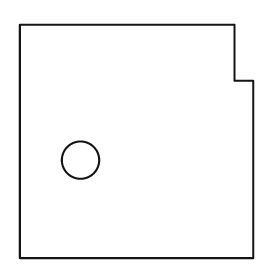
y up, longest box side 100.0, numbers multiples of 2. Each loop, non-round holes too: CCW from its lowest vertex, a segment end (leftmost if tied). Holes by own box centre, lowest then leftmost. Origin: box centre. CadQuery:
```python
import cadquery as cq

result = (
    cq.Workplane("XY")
    .moveTo(-50.0, -50.0)
    .lineTo(50.0, -50.0)
    .lineTo(50.0, 26.0)
    .lineTo(42.0, 26.0)
    .lineTo(42.0, 50.0)
    .lineTo(-50.0, 50.0)
    .close()
    .moveTo(-24.0, -8.0)
    .circle(8.0)
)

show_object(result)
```